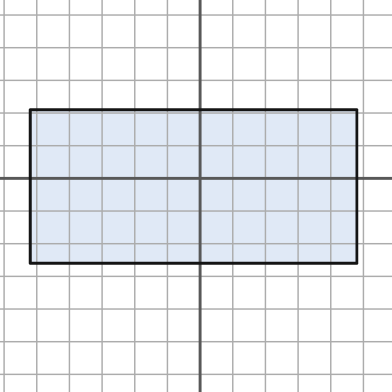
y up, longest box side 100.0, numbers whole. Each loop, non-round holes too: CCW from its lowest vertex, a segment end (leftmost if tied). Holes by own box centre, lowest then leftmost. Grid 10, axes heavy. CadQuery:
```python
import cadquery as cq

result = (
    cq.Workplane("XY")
    .moveTo(-52.0, -26.0)
    .lineTo(48.0, -26.0)
    .lineTo(48.0, 21.0)
    .lineTo(-52.0, 21.0)
    .close()
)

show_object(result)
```